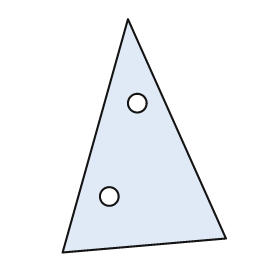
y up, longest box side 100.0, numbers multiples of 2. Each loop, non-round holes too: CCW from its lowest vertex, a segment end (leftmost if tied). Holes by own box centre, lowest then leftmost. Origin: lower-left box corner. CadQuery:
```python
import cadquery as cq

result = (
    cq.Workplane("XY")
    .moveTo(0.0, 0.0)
    .lineTo(70.0, 6.0)
    .lineTo(28.0, 100.0)
    .close()
    .moveTo(20.0, 24.0)
    .circle(4.0)
    .moveTo(32.0, 64.0)
    .circle(4.0)
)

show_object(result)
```